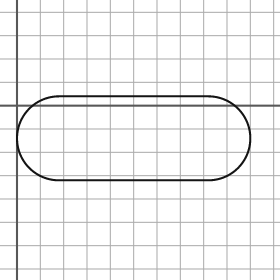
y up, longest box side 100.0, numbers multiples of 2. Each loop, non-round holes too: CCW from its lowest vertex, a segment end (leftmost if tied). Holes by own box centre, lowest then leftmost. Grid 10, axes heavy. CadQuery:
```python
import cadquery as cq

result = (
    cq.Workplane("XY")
    .moveTo(18.0, -32.0)
    .lineTo(82.0, -32.0)
    .threePointArc((100.0, -14.0), (82.0, 4.0))
    .lineTo(18.0, 4.0)
    .threePointArc((0.0, -14.0), (18.0, -32.0))
    .close()
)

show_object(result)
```